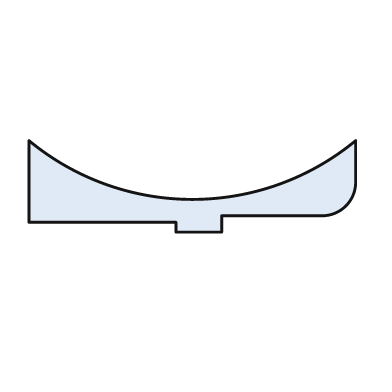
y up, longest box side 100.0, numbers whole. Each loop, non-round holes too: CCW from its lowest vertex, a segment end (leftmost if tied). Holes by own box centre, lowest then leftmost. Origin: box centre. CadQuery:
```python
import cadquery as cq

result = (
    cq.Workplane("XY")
    .moveTo(-5.0, -14.0)
    .lineTo(9.0, -14.0)
    .lineTo(9.0, -9.0)
    .lineTo(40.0, -9.0)
    .threePointArc((47.0, -6.0), (50.0, 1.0))
    .lineTo(50.0, 14.0)
    .threePointArc((0.0, -4.0), (-50.0, 14.0))
    .lineTo(-50.0, -11.0)
    .lineTo(-5.0, -11.0)
    .close()
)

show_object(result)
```